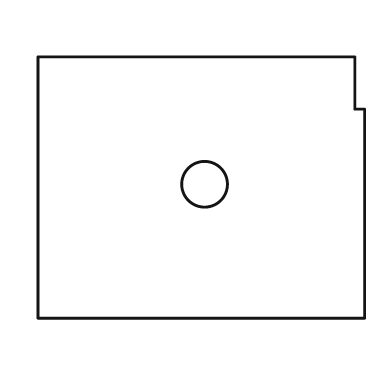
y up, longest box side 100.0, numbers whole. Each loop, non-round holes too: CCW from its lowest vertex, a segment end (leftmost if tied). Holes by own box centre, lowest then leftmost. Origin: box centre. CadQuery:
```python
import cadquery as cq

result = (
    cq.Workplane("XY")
    .moveTo(-50.0, -40.0)
    .lineTo(50.0, -40.0)
    .lineTo(50.0, 24.0)
    .lineTo(47.0, 24.0)
    .lineTo(47.0, 40.0)
    .lineTo(-50.0, 40.0)
    .close()
    .moveTo(1.0, 1.0)
    .circle(7.0)
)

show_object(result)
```